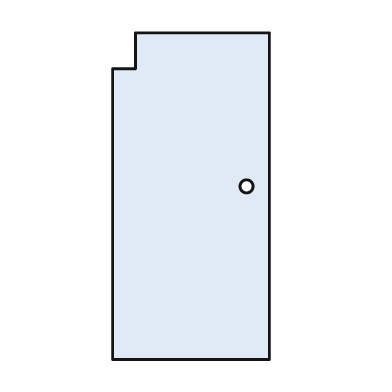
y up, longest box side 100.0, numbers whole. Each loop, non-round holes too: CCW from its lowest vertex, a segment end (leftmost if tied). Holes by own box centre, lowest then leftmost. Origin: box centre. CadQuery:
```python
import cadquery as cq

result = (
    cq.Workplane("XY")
    .moveTo(-24.0, -50.0)
    .lineTo(24.0, -50.0)
    .lineTo(24.0, 50.0)
    .lineTo(-17.0, 50.0)
    .lineTo(-17.0, 39.0)
    .lineTo(-24.0, 39.0)
    .close()
    .moveTo(17.0, 3.0)
    .circle(2.0)
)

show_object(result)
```